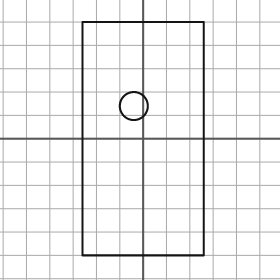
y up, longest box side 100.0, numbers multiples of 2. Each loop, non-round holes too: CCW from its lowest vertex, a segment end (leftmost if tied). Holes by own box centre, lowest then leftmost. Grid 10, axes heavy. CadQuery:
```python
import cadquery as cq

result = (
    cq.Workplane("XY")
    .moveTo(-26.0, -50.0)
    .lineTo(26.0, -50.0)
    .lineTo(26.0, 50.0)
    .lineTo(-26.0, 50.0)
    .close()
    .moveTo(-4.0, 14.0)
    .circle(6.0)
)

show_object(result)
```